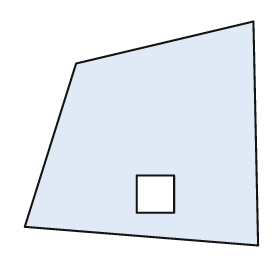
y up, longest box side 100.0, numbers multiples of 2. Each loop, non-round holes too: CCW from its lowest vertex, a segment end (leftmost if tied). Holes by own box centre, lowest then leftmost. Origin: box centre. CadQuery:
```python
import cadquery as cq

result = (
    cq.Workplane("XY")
    .moveTo(50.0, -48.0)
    .lineTo(48.0, 48.0)
    .lineTo(-28.0, 30.0)
    .lineTo(-50.0, -40.0)
    .close()
    .moveTo(-2.0, -34.0)
    .lineTo(14.0, -34.0)
    .lineTo(14.0, -18.0)
    .lineTo(-2.0, -18.0)
    .close()
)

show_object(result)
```